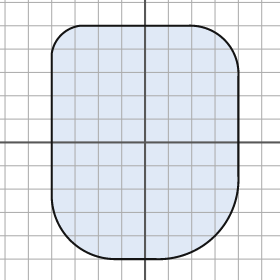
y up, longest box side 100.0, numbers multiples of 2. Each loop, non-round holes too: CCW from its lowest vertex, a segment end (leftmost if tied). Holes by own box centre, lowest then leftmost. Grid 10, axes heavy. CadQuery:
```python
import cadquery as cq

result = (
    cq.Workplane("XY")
    .moveTo(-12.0, -50.0)
    .lineTo(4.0, -50.0)
    .threePointArc((30.0, -40.0), (40.0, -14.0))
    .lineTo(40.0, 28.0)
    .threePointArc((34.0, 44.0), (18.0, 50.0))
    .lineTo(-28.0, 50.0)
    .threePointArc((-36.0, 46.0), (-40.0, 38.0))
    .lineTo(-40.0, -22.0)
    .threePointArc((-32.0, -42.0), (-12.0, -50.0))
    .close()
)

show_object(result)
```